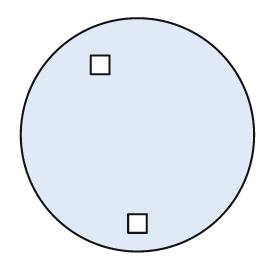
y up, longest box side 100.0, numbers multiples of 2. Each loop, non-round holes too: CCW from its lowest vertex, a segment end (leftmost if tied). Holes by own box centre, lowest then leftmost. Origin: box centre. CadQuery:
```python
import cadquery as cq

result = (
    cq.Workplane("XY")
    .moveTo(0.0, 0.0)
    .circle(50.0)
    .moveTo(-4.0, -42.0)
    .lineTo(4.0, -42.0)
    .lineTo(4.0, -34.0)
    .lineTo(-4.0, -34.0)
    .close()
    .moveTo(-20.0, 26.0)
    .lineTo(-12.0, 26.0)
    .lineTo(-12.0, 34.0)
    .lineTo(-20.0, 34.0)
    .close()
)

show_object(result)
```